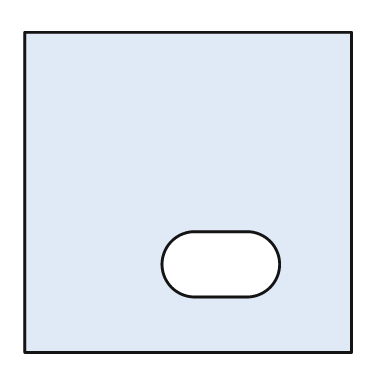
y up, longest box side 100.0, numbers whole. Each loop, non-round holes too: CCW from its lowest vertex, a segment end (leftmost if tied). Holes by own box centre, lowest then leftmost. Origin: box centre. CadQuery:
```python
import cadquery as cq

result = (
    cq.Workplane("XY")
    .moveTo(-50.0, -49.0)
    .lineTo(50.0, -49.0)
    .lineTo(50.0, 49.0)
    .lineTo(-50.0, 49.0)
    .close()
    .moveTo(2.0, -32.0)
    .lineTo(18.0, -32.0)
    .threePointArc((28.0, -22.0), (18.0, -12.0))
    .lineTo(2.0, -12.0)
    .threePointArc((-8.0, -22.0), (2.0, -32.0))
    .close()
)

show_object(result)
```